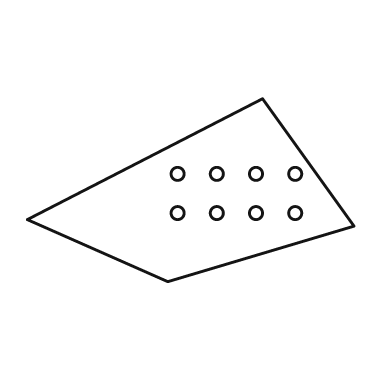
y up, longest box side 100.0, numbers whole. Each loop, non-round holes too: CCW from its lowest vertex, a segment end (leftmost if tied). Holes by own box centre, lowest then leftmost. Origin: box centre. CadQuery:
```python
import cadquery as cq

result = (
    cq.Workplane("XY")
    .moveTo(-7.0, -28.0)
    .lineTo(50.0, -11.0)
    .lineTo(22.0, 28.0)
    .lineTo(-50.0, -9.0)
    .close()
    .moveTo(-4.0, -7.0)
    .circle(2.0)
    .moveTo(8.0, -7.0)
    .circle(2.0)
    .moveTo(20.0, -7.0)
    .circle(2.0)
    .moveTo(32.0, -7.0)
    .circle(2.0)
    .moveTo(-4.0, 5.0)
    .circle(2.0)
    .moveTo(8.0, 5.0)
    .circle(2.0)
    .moveTo(20.0, 5.0)
    .circle(2.0)
    .moveTo(32.0, 5.0)
    .circle(2.0)
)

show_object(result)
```